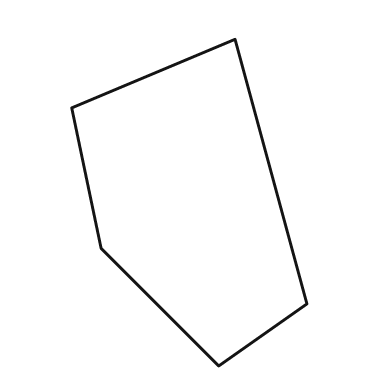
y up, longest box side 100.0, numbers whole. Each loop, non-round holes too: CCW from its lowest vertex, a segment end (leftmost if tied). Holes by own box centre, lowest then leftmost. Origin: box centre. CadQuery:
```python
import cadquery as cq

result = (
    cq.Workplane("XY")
    .moveTo(9.0, -50.0)
    .lineTo(36.0, -31.0)
    .lineTo(14.0, 50.0)
    .lineTo(-36.0, 29.0)
    .lineTo(-27.0, -14.0)
    .close()
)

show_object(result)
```